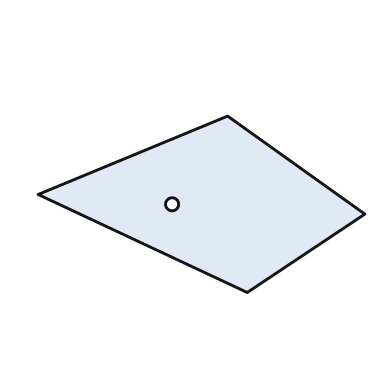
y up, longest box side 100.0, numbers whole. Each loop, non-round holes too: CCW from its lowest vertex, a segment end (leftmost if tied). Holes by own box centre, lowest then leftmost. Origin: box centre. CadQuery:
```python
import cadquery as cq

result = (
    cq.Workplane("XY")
    .moveTo(14.0, -27.0)
    .lineTo(50.0, -3.0)
    .lineTo(8.0, 27.0)
    .lineTo(-50.0, 3.0)
    .close()
    .moveTo(-9.0, 0.0)
    .circle(2.0)
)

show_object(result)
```